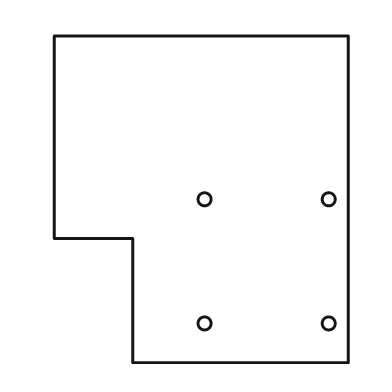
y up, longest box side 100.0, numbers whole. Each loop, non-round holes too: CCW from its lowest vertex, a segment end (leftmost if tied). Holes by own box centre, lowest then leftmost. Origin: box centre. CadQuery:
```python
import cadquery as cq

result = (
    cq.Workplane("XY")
    .moveTo(-21.0, -50.0)
    .lineTo(45.0, -50.0)
    .lineTo(45.0, 50.0)
    .lineTo(-45.0, 50.0)
    .lineTo(-45.0, -12.0)
    .lineTo(-21.0, -12.0)
    .close()
    .moveTo(1.0, -38.0)
    .circle(2.0)
    .moveTo(39.0, -38.0)
    .circle(2.0)
    .moveTo(1.0, 0.0)
    .circle(2.0)
    .moveTo(39.0, 0.0)
    .circle(2.0)
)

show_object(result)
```